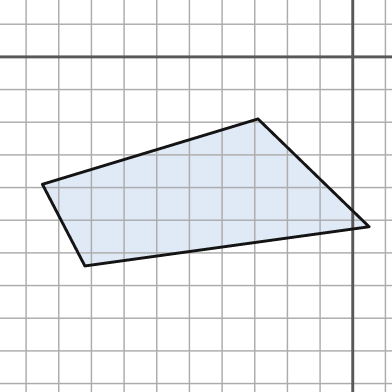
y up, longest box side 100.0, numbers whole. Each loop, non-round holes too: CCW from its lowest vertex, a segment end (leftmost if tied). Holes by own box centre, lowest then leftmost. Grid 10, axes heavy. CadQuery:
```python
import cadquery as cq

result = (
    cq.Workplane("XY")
    .moveTo(-82.0, -64.0)
    .lineTo(5.0, -52.0)
    .lineTo(-29.0, -19.0)
    .lineTo(-95.0, -39.0)
    .close()
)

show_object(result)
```